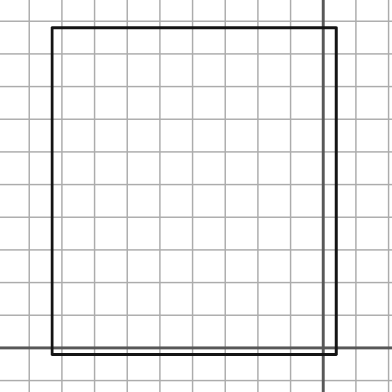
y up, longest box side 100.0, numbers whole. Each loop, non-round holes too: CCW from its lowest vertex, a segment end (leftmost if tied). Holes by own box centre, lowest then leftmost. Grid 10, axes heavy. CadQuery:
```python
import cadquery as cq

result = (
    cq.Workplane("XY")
    .moveTo(-83.0, -2.0)
    .lineTo(4.0, -2.0)
    .lineTo(4.0, 98.0)
    .lineTo(-83.0, 98.0)
    .close()
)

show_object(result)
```